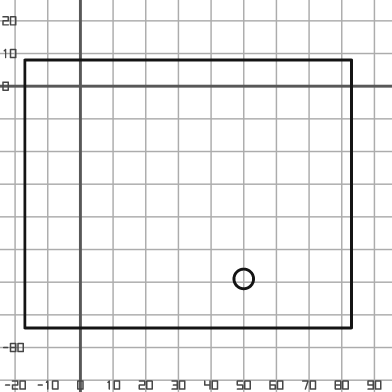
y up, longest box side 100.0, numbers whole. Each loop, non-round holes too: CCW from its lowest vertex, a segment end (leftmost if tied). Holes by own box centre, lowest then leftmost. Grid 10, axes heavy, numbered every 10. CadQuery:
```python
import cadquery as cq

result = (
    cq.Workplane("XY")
    .moveTo(-17.0, -74.0)
    .lineTo(83.0, -74.0)
    .lineTo(83.0, 8.0)
    .lineTo(-17.0, 8.0)
    .close()
    .moveTo(50.0, -59.0)
    .circle(3.0)
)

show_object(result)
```